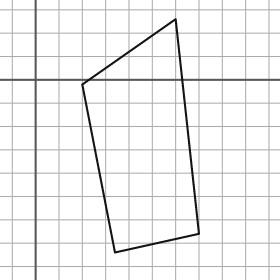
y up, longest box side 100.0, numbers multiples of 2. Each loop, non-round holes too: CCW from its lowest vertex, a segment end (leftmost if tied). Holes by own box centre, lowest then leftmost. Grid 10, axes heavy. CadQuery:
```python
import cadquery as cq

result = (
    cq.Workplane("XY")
    .moveTo(34.0, -74.0)
    .lineTo(70.0, -66.0)
    .lineTo(60.0, 26.0)
    .lineTo(20.0, -2.0)
    .close()
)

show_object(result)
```